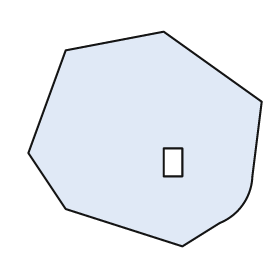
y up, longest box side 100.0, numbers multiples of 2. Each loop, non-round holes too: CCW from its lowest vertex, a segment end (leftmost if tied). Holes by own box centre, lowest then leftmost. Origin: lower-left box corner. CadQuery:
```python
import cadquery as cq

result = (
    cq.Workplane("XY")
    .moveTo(66.0, 0.0)
    .lineTo(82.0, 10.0)
    .threePointArc((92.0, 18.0), (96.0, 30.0))
    .lineTo(100.0, 62.0)
    .lineTo(58.0, 92.0)
    .lineTo(16.0, 84.0)
    .lineTo(0.0, 40.0)
    .lineTo(16.0, 16.0)
    .close()
    .moveTo(58.0, 30.0)
    .lineTo(66.0, 30.0)
    .lineTo(66.0, 42.0)
    .lineTo(58.0, 42.0)
    .close()
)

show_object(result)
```